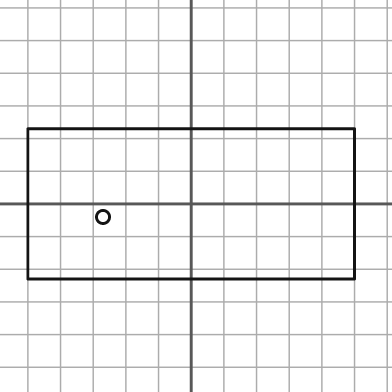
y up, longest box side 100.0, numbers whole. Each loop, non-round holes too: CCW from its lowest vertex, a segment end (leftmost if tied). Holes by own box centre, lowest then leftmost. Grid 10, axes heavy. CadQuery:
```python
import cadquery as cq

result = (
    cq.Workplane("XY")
    .moveTo(-50.0, -23.0)
    .lineTo(50.0, -23.0)
    .lineTo(50.0, 23.0)
    .lineTo(-50.0, 23.0)
    .close()
    .moveTo(-27.0, -4.0)
    .circle(2.0)
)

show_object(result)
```